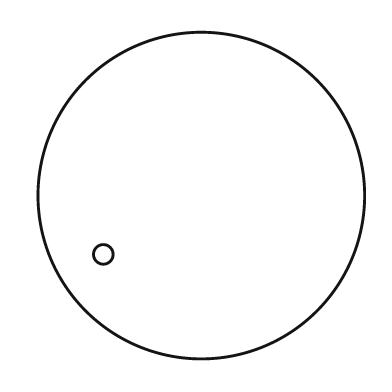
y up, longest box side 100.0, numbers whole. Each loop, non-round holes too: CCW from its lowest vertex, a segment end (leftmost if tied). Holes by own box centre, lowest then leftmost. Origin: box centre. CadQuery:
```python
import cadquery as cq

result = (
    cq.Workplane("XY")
    .moveTo(0.0, 0.0)
    .circle(50.0)
    .moveTo(-30.0, -18.0)
    .circle(3.0)
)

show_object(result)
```